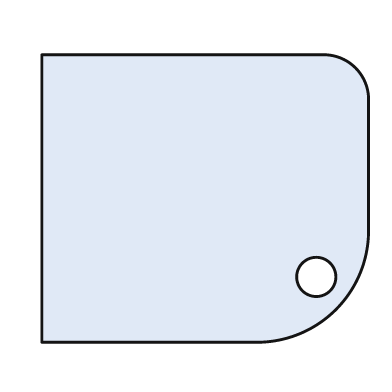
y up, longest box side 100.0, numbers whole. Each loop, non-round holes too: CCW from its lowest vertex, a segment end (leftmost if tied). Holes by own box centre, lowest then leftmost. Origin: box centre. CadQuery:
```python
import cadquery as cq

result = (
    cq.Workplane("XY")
    .moveTo(-50.0, -44.0)
    .lineTo(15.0, -44.0)
    .threePointArc((40.0, -34.0), (50.0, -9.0))
    .lineTo(50.0, 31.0)
    .threePointArc((46.0, 40.0), (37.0, 44.0))
    .lineTo(-50.0, 44.0)
    .close()
    .moveTo(34.0, -24.0)
    .circle(6.0)
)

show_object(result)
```